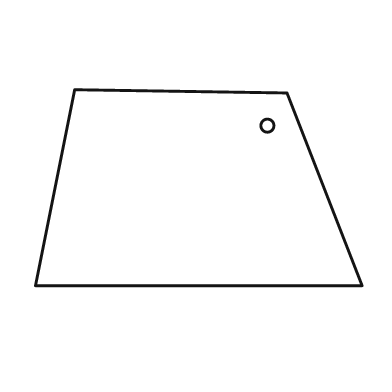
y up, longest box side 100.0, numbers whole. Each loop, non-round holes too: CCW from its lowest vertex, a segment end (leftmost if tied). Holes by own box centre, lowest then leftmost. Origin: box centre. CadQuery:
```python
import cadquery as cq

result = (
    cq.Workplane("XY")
    .moveTo(-50.0, -30.0)
    .lineTo(50.0, -30.0)
    .lineTo(27.0, 29.0)
    .lineTo(-38.0, 30.0)
    .close()
    .moveTo(21.0, 19.0)
    .circle(2.0)
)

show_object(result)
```